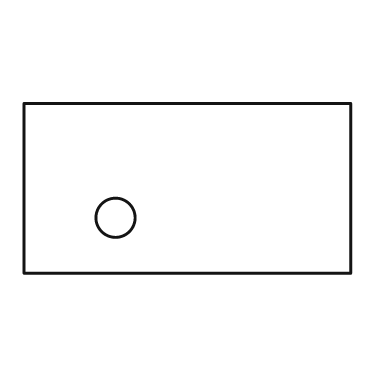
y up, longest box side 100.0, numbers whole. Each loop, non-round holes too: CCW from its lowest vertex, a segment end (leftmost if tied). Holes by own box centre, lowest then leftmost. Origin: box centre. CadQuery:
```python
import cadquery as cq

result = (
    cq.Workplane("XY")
    .moveTo(-50.0, -26.0)
    .lineTo(50.0, -26.0)
    .lineTo(50.0, 26.0)
    .lineTo(-50.0, 26.0)
    .close()
    .moveTo(-22.0, -9.0)
    .circle(6.0)
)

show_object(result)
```